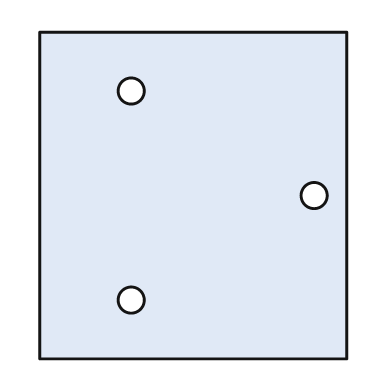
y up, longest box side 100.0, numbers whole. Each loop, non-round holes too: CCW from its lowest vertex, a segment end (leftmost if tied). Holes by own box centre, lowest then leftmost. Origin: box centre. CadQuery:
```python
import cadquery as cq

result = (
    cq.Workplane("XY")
    .moveTo(-47.0, -50.0)
    .lineTo(47.0, -50.0)
    .lineTo(47.0, 50.0)
    .lineTo(-47.0, 50.0)
    .close()
    .moveTo(-19.0, -32.0)
    .circle(4.0)
    .moveTo(37.0, 0.0)
    .circle(4.0)
    .moveTo(-19.0, 32.0)
    .circle(4.0)
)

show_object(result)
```